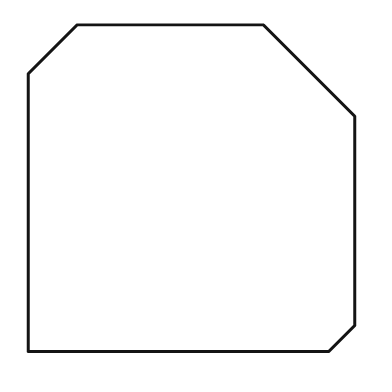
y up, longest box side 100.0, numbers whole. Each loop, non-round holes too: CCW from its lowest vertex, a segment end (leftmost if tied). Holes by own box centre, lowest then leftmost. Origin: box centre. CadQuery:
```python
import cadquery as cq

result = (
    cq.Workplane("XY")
    .moveTo(-50.0, -50.0)
    .lineTo(42.0, -50.0)
    .lineTo(50.0, -42.0)
    .lineTo(50.0, 22.0)
    .lineTo(22.0, 50.0)
    .lineTo(-35.0, 50.0)
    .lineTo(-50.0, 35.0)
    .close()
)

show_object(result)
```